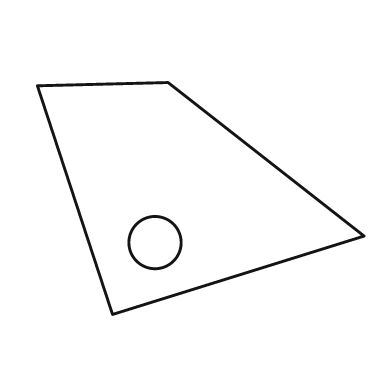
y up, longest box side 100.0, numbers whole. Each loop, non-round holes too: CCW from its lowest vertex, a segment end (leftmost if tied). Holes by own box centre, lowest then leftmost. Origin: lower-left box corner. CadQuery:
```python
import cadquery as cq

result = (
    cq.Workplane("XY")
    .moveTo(23.0, 0.0)
    .lineTo(100.0, 24.0)
    .lineTo(40.0, 71.0)
    .lineTo(0.0, 70.0)
    .close()
    .moveTo(36.0, 22.0)
    .circle(8.0)
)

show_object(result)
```